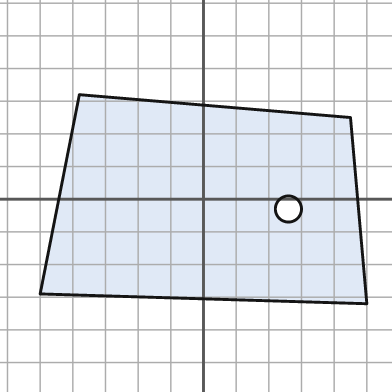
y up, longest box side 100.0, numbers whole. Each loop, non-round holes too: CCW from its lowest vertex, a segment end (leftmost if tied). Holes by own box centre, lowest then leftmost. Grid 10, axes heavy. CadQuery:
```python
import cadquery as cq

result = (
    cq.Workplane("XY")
    .moveTo(50.0, -32.0)
    .lineTo(45.0, 25.0)
    .lineTo(-38.0, 32.0)
    .lineTo(-50.0, -29.0)
    .close()
    .moveTo(26.0, -3.0)
    .circle(4.0)
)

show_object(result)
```